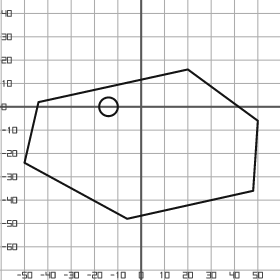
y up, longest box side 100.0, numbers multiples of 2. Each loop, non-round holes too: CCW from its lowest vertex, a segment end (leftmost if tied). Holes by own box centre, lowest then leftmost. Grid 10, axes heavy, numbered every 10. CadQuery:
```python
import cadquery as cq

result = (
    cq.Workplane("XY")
    .moveTo(-6.0, -48.0)
    .lineTo(48.0, -36.0)
    .lineTo(50.0, -6.0)
    .lineTo(20.0, 16.0)
    .lineTo(-44.0, 2.0)
    .lineTo(-50.0, -24.0)
    .close()
    .moveTo(-14.0, 0.0)
    .circle(4.0)
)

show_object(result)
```